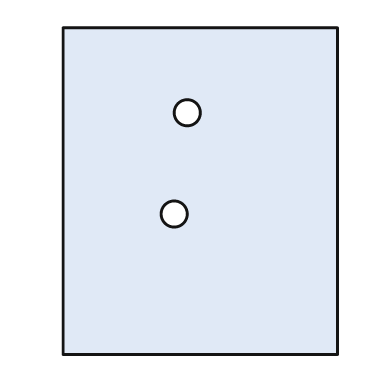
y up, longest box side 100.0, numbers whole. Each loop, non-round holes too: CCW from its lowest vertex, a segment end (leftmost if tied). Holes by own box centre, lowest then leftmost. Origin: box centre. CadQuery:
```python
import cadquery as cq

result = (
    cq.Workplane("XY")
    .moveTo(-42.0, -50.0)
    .lineTo(42.0, -50.0)
    .lineTo(42.0, 50.0)
    .lineTo(-42.0, 50.0)
    .close()
    .moveTo(-8.0, -7.0)
    .circle(4.0)
    .moveTo(-4.0, 24.0)
    .circle(4.0)
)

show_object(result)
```